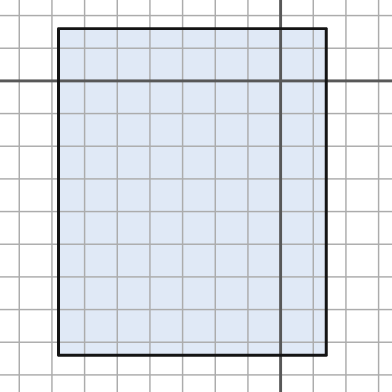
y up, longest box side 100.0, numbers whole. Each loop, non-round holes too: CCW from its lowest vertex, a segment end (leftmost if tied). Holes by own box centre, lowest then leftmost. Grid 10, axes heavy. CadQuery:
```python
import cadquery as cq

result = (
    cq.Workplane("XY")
    .moveTo(-68.0, -84.0)
    .lineTo(14.0, -84.0)
    .lineTo(14.0, 16.0)
    .lineTo(-68.0, 16.0)
    .close()
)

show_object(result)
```